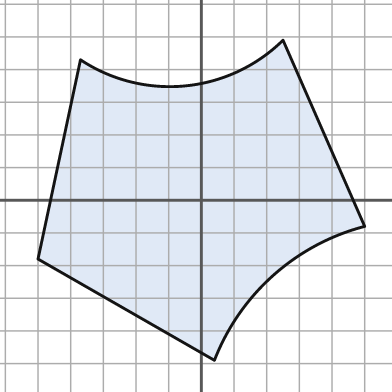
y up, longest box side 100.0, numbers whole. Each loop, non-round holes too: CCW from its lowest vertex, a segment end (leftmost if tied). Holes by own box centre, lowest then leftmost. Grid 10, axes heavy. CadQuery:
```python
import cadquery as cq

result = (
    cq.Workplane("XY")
    .moveTo(4.0, -49.0)
    .threePointArc((22.0, -23.0), (50.0, -8.0))
    .lineTo(25.0, 49.0)
    .threePointArc((-5.0, 35.0), (-37.0, 43.0))
    .lineTo(-50.0, -18.0)
    .close()
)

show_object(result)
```